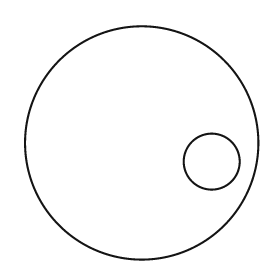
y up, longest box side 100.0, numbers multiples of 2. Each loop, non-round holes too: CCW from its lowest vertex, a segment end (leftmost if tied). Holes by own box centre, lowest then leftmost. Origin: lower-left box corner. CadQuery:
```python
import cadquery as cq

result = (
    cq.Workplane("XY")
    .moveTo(50.0, 50.0)
    .circle(50.0)
    .moveTo(80.0, 42.0)
    .circle(12.0)
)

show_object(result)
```